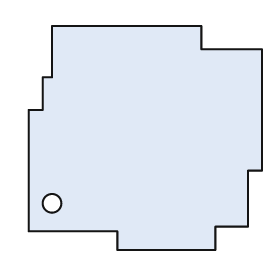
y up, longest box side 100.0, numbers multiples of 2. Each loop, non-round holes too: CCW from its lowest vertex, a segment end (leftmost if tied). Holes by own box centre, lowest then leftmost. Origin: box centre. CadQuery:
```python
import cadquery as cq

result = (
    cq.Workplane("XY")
    .moveTo(-12.0, -48.0)
    .lineTo(30.0, -48.0)
    .lineTo(30.0, -38.0)
    .lineTo(44.0, -38.0)
    .lineTo(44.0, -14.0)
    .lineTo(50.0, -14.0)
    .lineTo(50.0, 38.0)
    .lineTo(24.0, 38.0)
    .lineTo(24.0, 48.0)
    .lineTo(-40.0, 48.0)
    .lineTo(-40.0, 26.0)
    .lineTo(-44.0, 26.0)
    .lineTo(-44.0, 12.0)
    .lineTo(-50.0, 12.0)
    .lineTo(-50.0, -40.0)
    .lineTo(-12.0, -40.0)
    .close()
    .moveTo(-40.0, -28.0)
    .circle(4.0)
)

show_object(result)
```